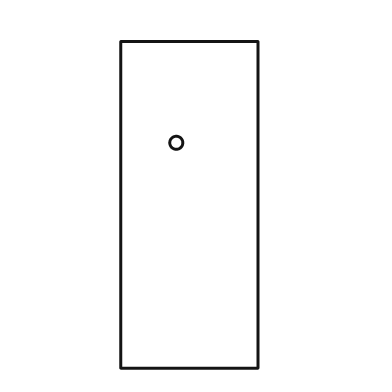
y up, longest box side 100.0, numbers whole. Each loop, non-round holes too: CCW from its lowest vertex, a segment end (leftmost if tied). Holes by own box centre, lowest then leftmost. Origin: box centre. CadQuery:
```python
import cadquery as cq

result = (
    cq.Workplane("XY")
    .moveTo(-21.0, -50.0)
    .lineTo(21.0, -50.0)
    .lineTo(21.0, 50.0)
    .lineTo(-21.0, 50.0)
    .close()
    .moveTo(-4.0, 19.0)
    .circle(2.0)
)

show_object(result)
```